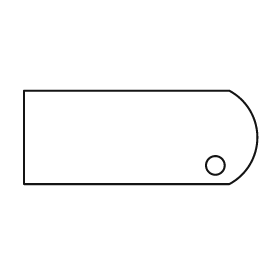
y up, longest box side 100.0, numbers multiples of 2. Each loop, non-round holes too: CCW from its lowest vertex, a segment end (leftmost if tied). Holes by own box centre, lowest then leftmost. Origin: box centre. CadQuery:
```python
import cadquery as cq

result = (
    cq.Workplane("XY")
    .moveTo(-50.0, -20.0)
    .lineTo(38.0, -20.0)
    .threePointArc((50.0, 0.0), (38.0, 20.0))
    .lineTo(-50.0, 20.0)
    .close()
    .moveTo(32.0, -12.0)
    .circle(4.0)
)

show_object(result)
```